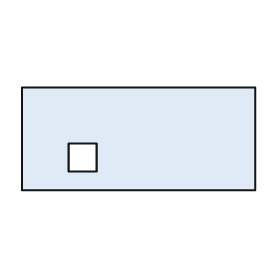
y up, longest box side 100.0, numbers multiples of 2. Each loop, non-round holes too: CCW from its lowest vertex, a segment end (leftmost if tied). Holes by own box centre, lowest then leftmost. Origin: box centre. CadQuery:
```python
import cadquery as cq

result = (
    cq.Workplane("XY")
    .moveTo(-50.0, -22.0)
    .lineTo(50.0, -22.0)
    .lineTo(50.0, 22.0)
    .lineTo(-50.0, 22.0)
    .close()
    .moveTo(-30.0, -14.0)
    .lineTo(-18.0, -14.0)
    .lineTo(-18.0, -2.0)
    .lineTo(-30.0, -2.0)
    .close()
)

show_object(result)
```